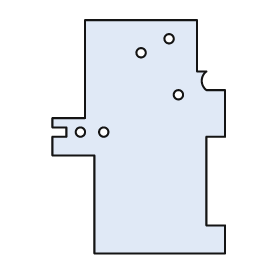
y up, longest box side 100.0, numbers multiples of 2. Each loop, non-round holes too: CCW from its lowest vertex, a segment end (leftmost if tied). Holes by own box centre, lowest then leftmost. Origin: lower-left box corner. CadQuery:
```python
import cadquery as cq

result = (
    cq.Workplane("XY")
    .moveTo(18.0, 0.0)
    .lineTo(74.0, 0.0)
    .lineTo(74.0, 12.0)
    .lineTo(66.0, 12.0)
    .lineTo(66.0, 50.0)
    .lineTo(74.0, 50.0)
    .lineTo(74.0, 70.0)
    .lineTo(66.0, 70.0)
    .threePointArc((64.0, 74.0), (66.0, 78.0))
    .lineTo(62.0, 78.0)
    .lineTo(62.0, 100.0)
    .lineTo(14.0, 100.0)
    .lineTo(14.0, 58.0)
    .lineTo(0.0, 58.0)
    .lineTo(0.0, 54.0)
    .lineTo(6.0, 54.0)
    .lineTo(6.0, 50.0)
    .lineTo(0.0, 50.0)
    .lineTo(0.0, 42.0)
    .lineTo(18.0, 42.0)
    .close()
    .moveTo(12.0, 52.0)
    .circle(2.0)
    .moveTo(22.0, 52.0)
    .circle(2.0)
    .moveTo(54.0, 68.0)
    .circle(2.0)
    .moveTo(38.0, 86.0)
    .circle(2.0)
    .moveTo(50.0, 92.0)
    .circle(2.0)
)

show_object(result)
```